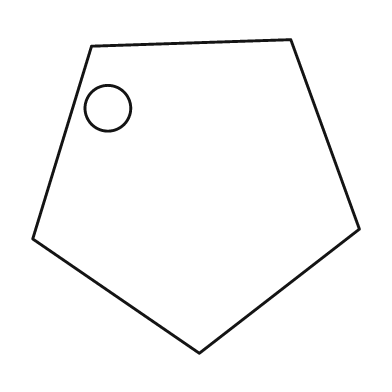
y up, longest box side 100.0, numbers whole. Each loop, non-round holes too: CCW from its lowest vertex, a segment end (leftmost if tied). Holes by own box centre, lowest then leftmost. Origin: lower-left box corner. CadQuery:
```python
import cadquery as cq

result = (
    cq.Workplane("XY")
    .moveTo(51.0, 0.0)
    .lineTo(100.0, 38.0)
    .lineTo(79.0, 96.0)
    .lineTo(18.0, 94.0)
    .lineTo(0.0, 35.0)
    .close()
    .moveTo(23.0, 75.0)
    .circle(7.0)
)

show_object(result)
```